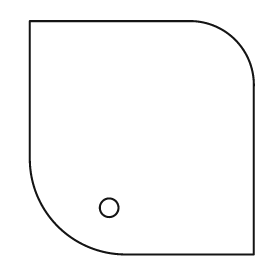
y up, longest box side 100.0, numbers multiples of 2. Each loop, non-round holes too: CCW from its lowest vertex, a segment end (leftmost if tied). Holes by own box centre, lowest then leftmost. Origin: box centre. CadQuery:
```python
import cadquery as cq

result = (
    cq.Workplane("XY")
    .moveTo(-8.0, -50.0)
    .lineTo(48.0, -50.0)
    .lineTo(48.0, 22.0)
    .threePointArc((40.0, 42.0), (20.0, 50.0))
    .lineTo(-48.0, 50.0)
    .lineTo(-48.0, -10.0)
    .threePointArc((-36.0, -38.0), (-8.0, -50.0))
    .close()
    .moveTo(-14.0, -30.0)
    .circle(4.0)
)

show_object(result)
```